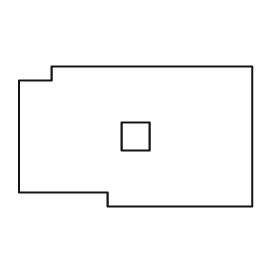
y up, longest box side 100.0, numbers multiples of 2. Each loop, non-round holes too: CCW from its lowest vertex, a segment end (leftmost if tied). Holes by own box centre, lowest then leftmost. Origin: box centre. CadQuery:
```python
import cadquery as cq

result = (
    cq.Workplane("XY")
    .moveTo(-12.0, -30.0)
    .lineTo(50.0, -30.0)
    .lineTo(50.0, 30.0)
    .lineTo(-36.0, 30.0)
    .lineTo(-36.0, 24.0)
    .lineTo(-50.0, 24.0)
    .lineTo(-50.0, -24.0)
    .lineTo(-12.0, -24.0)
    .close()
    .moveTo(-6.0, -6.0)
    .lineTo(6.0, -6.0)
    .lineTo(6.0, 6.0)
    .lineTo(-6.0, 6.0)
    .close()
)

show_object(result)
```